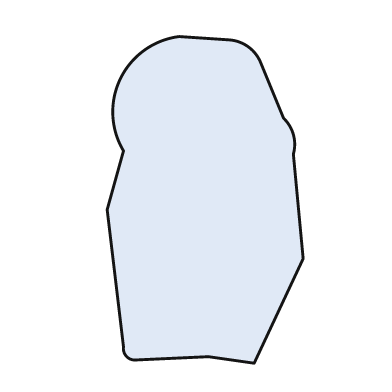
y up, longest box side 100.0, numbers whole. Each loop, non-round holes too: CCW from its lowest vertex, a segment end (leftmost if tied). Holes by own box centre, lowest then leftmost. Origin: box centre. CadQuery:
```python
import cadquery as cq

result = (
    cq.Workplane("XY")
    .moveTo(15.0, -50.0)
    .lineTo(30.0, -18.0)
    .lineTo(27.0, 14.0)
    .threePointArc((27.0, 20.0), (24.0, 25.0))
    .lineTo(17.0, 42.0)
    .threePointArc((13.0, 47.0), (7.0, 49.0))
    .lineTo(-8.0, 50.0)
    .threePointArc((-26.0, 37.0), (-25.0, 15.0))
    .lineTo(-30.0, -3.0)
    .lineTo(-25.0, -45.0)
    .threePointArc((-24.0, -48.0), (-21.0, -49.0))
    .lineTo(1.0, -48.0)
    .close()
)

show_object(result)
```